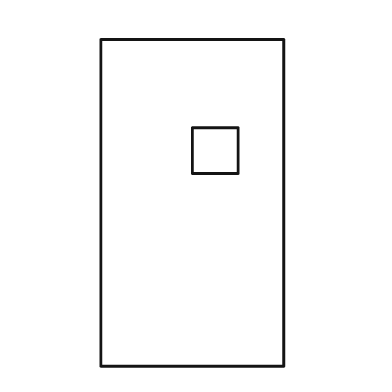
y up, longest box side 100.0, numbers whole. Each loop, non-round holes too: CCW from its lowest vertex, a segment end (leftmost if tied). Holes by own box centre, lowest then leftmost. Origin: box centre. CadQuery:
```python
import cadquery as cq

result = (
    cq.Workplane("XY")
    .moveTo(-28.0, -50.0)
    .lineTo(28.0, -50.0)
    .lineTo(28.0, 50.0)
    .lineTo(-28.0, 50.0)
    .close()
    .moveTo(0.0, 9.0)
    .lineTo(14.0, 9.0)
    .lineTo(14.0, 23.0)
    .lineTo(0.0, 23.0)
    .close()
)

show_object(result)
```